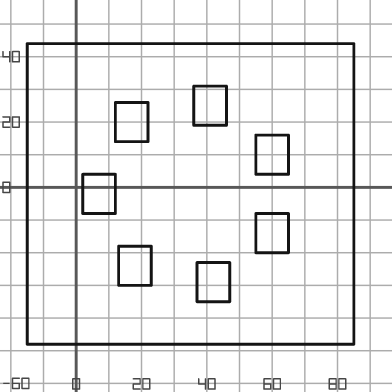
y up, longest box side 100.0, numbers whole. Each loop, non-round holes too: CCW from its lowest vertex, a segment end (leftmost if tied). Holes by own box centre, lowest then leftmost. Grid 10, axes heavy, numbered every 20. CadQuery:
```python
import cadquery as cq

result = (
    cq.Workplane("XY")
    .moveTo(-15.0, -48.0)
    .lineTo(85.0, -48.0)
    .lineTo(85.0, 44.0)
    .lineTo(-15.0, 44.0)
    .close()
    .moveTo(37.0, -35.0)
    .lineTo(47.0, -35.0)
    .lineTo(47.0, -23.0)
    .lineTo(37.0, -23.0)
    .close()
    .moveTo(13.0, -30.0)
    .lineTo(23.0, -30.0)
    .lineTo(23.0, -18.0)
    .lineTo(13.0, -18.0)
    .close()
    .moveTo(55.0, -20.0)
    .lineTo(65.0, -20.0)
    .lineTo(65.0, -8.0)
    .lineTo(55.0, -8.0)
    .close()
    .moveTo(2.0, -8.0)
    .lineTo(12.0, -8.0)
    .lineTo(12.0, 4.0)
    .lineTo(2.0, 4.0)
    .close()
    .moveTo(55.0, 4.0)
    .lineTo(65.0, 4.0)
    .lineTo(65.0, 16.0)
    .lineTo(55.0, 16.0)
    .close()
    .moveTo(12.0, 14.0)
    .lineTo(22.0, 14.0)
    .lineTo(22.0, 26.0)
    .lineTo(12.0, 26.0)
    .close()
    .moveTo(36.0, 19.0)
    .lineTo(46.0, 19.0)
    .lineTo(46.0, 31.0)
    .lineTo(36.0, 31.0)
    .close()
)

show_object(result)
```